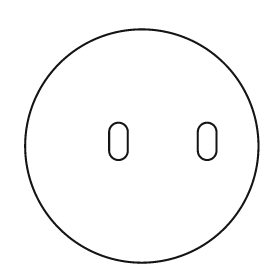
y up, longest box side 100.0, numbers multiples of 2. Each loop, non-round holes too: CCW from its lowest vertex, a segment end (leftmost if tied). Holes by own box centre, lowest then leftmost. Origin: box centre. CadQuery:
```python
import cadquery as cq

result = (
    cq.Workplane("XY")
    .moveTo(0.0, 0.0)
    .circle(50.0)
    .moveTo(-14.0, -2.0)
    .threePointArc((-10.0, -6.0), (-6.0, -2.0))
    .lineTo(-6.0, 6.0)
    .threePointArc((-10.0, 10.0), (-14.0, 6.0))
    .close()
    .moveTo(24.0, -2.0)
    .threePointArc((28.0, -6.0), (32.0, -2.0))
    .lineTo(32.0, 6.0)
    .threePointArc((28.0, 10.0), (24.0, 6.0))
    .close()
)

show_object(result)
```